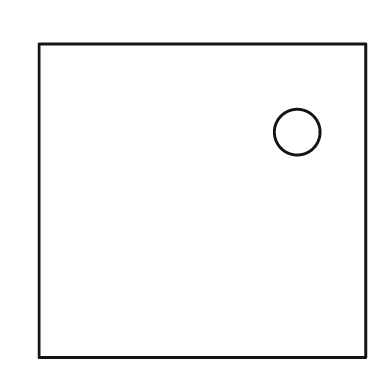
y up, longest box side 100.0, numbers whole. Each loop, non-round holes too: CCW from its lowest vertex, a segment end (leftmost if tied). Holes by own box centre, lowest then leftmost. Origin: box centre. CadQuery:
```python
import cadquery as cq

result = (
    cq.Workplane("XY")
    .moveTo(-50.0, -48.0)
    .lineTo(50.0, -48.0)
    .lineTo(50.0, 48.0)
    .lineTo(-50.0, 48.0)
    .close()
    .moveTo(29.0, 21.0)
    .circle(7.0)
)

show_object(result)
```